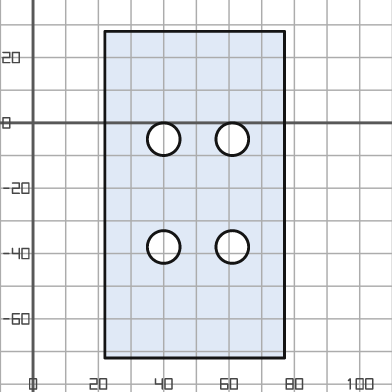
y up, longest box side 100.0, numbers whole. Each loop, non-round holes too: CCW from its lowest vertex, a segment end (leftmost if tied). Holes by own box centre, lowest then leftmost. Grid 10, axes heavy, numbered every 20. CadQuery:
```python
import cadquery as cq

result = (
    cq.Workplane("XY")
    .moveTo(22.0, -72.0)
    .lineTo(77.0, -72.0)
    .lineTo(77.0, 28.0)
    .lineTo(22.0, 28.0)
    .close()
    .moveTo(40.0, -38.0)
    .circle(5.0)
    .moveTo(61.0, -38.0)
    .circle(5.0)
    .moveTo(40.0, -5.0)
    .circle(5.0)
    .moveTo(61.0, -5.0)
    .circle(5.0)
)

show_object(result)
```